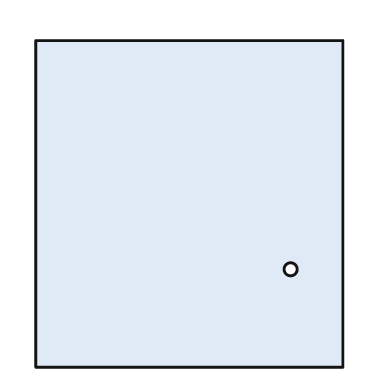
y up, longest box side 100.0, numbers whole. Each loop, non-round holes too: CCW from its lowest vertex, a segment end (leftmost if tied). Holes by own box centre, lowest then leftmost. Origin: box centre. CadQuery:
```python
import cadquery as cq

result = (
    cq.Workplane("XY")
    .moveTo(-47.0, -50.0)
    .lineTo(47.0, -50.0)
    .lineTo(47.0, 50.0)
    .lineTo(-47.0, 50.0)
    .close()
    .moveTo(31.0, -20.0)
    .circle(2.0)
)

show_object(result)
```